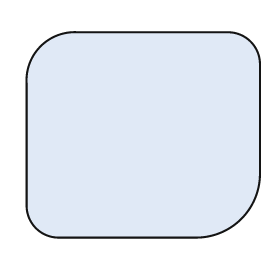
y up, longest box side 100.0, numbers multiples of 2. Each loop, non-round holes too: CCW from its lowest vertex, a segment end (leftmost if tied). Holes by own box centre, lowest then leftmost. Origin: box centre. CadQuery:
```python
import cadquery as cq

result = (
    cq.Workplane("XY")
    .moveTo(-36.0, -44.0)
    .lineTo(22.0, -44.0)
    .threePointArc((42.0, -36.0), (50.0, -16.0))
    .lineTo(50.0, 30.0)
    .threePointArc((46.0, 40.0), (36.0, 44.0))
    .lineTo(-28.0, 44.0)
    .threePointArc((-44.0, 38.0), (-50.0, 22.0))
    .lineTo(-50.0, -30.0)
    .threePointArc((-46.0, -40.0), (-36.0, -44.0))
    .close()
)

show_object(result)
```